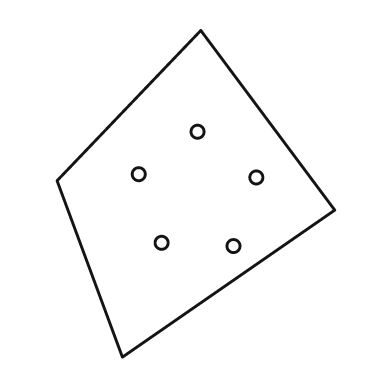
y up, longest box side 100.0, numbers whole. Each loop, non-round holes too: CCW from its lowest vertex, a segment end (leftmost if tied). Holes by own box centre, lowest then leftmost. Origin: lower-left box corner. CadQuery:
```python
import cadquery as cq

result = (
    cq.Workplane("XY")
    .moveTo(20.0, 0.0)
    .lineTo(85.0, 45.0)
    .lineTo(44.0, 100.0)
    .lineTo(0.0, 54.0)
    .close()
    .moveTo(54.0, 34.0)
    .circle(2.0)
    .moveTo(32.0, 35.0)
    .circle(2.0)
    .moveTo(61.0, 55.0)
    .circle(2.0)
    .moveTo(25.0, 56.0)
    .circle(2.0)
    .moveTo(43.0, 69.0)
    .circle(2.0)
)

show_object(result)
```